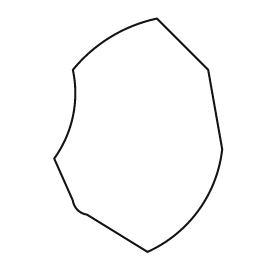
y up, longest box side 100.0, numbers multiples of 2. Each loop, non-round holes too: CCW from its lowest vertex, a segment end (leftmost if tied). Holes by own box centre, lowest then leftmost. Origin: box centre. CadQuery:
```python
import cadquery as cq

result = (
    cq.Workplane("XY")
    .moveTo(4.0, -50.0)
    .threePointArc((26.0, -32.0), (36.0, -6.0))
    .lineTo(30.0, 28.0)
    .lineTo(8.0, 50.0)
    .threePointArc((-12.0, 42.0), (-28.0, 28.0))
    .threePointArc((-28.0, 8.0), (-36.0, -10.0))
    .lineTo(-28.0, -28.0)
    .threePointArc((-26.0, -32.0), (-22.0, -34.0))
    .close()
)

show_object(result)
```